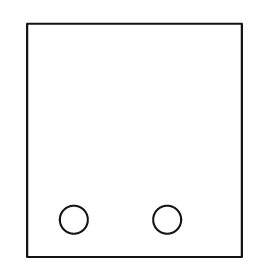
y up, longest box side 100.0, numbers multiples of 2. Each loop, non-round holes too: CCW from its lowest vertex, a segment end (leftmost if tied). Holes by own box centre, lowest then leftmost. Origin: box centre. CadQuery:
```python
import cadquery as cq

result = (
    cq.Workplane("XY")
    .moveTo(-46.0, -50.0)
    .lineTo(46.0, -50.0)
    .lineTo(46.0, 50.0)
    .lineTo(-46.0, 50.0)
    .close()
    .moveTo(-26.0, -34.0)
    .circle(6.0)
    .moveTo(14.0, -34.0)
    .circle(6.0)
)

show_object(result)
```